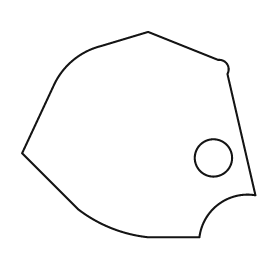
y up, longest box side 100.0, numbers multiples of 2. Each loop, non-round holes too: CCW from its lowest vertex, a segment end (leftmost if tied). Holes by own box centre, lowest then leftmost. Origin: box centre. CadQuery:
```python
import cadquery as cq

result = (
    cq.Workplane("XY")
    .moveTo(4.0, -44.0)
    .lineTo(26.0, -44.0)
    .threePointArc((34.0, -30.0), (50.0, -26.0))
    .lineTo(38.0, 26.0)
    .threePointArc((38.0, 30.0), (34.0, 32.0))
    .lineTo(4.0, 44.0)
    .lineTo(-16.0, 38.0)
    .threePointArc((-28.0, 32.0), (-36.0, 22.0))
    .lineTo(-50.0, -8.0)
    .lineTo(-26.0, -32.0)
    .threePointArc((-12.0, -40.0), (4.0, -44.0))
    .close()
    .moveTo(32.0, -10.0)
    .circle(8.0)
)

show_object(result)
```